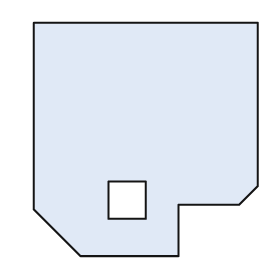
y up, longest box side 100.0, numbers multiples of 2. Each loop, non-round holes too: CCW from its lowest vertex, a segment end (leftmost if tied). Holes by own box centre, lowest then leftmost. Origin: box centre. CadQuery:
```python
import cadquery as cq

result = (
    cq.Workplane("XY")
    .moveTo(-28.0, -50.0)
    .lineTo(14.0, -50.0)
    .lineTo(14.0, -28.0)
    .lineTo(40.0, -28.0)
    .lineTo(48.0, -20.0)
    .lineTo(48.0, 50.0)
    .lineTo(-48.0, 50.0)
    .lineTo(-48.0, -30.0)
    .close()
    .moveTo(-16.0, -34.0)
    .lineTo(0.0, -34.0)
    .lineTo(0.0, -18.0)
    .lineTo(-16.0, -18.0)
    .close()
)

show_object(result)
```